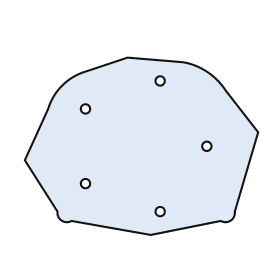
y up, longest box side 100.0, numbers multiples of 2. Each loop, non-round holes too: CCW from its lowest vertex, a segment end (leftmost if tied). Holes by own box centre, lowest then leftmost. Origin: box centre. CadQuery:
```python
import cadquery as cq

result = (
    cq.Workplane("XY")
    .moveTo(4.0, -38.0)
    .lineTo(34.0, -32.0)
    .threePointArc((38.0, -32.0), (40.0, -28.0))
    .lineTo(50.0, 6.0)
    .lineTo(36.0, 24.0)
    .threePointArc((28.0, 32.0), (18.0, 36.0))
    .lineTo(-6.0, 38.0)
    .lineTo(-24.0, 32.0)
    .threePointArc((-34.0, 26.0), (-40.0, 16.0))
    .lineTo(-50.0, -6.0)
    .lineTo(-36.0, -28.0)
    .threePointArc((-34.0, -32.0), (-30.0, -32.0))
    .close()
    .moveTo(8.0, -28.0)
    .circle(2.0)
    .moveTo(-24.0, -16.0)
    .circle(2.0)
    .moveTo(28.0, 0.0)
    .circle(2.0)
    .moveTo(-24.0, 16.0)
    .circle(2.0)
    .moveTo(8.0, 28.0)
    .circle(2.0)
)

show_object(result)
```